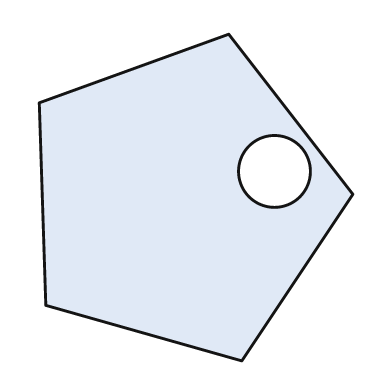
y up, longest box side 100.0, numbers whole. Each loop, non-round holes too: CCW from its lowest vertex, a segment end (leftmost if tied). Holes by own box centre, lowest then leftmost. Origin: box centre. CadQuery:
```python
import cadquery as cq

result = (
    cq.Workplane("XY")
    .moveTo(14.0, -50.0)
    .lineTo(48.0, 1.0)
    .lineTo(10.0, 50.0)
    .lineTo(-48.0, 29.0)
    .lineTo(-46.0, -33.0)
    .close()
    .moveTo(24.0, 8.0)
    .circle(11.0)
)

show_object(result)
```